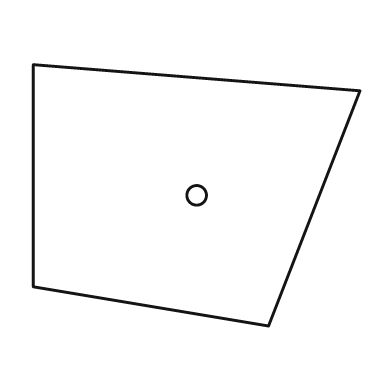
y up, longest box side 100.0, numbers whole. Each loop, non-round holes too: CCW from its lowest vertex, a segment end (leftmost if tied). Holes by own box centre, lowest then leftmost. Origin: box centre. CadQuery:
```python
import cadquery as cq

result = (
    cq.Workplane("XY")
    .moveTo(22.0, -40.0)
    .lineTo(50.0, 32.0)
    .lineTo(-50.0, 40.0)
    .lineTo(-50.0, -28.0)
    .close()
    .moveTo(0.0, 0.0)
    .circle(3.0)
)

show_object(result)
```